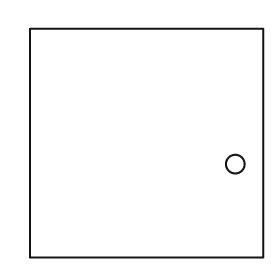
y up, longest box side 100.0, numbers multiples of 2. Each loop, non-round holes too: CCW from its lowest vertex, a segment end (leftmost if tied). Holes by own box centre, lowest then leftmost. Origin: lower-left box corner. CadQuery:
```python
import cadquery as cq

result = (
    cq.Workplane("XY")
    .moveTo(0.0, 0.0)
    .lineTo(100.0, 0.0)
    .lineTo(100.0, 98.0)
    .lineTo(0.0, 98.0)
    .close()
    .moveTo(88.0, 40.0)
    .circle(4.0)
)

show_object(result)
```